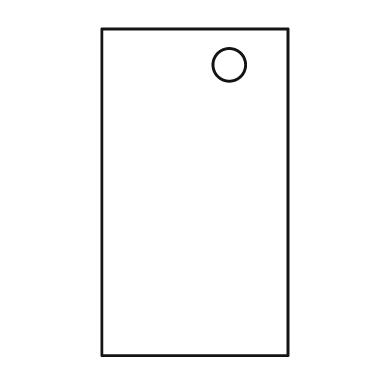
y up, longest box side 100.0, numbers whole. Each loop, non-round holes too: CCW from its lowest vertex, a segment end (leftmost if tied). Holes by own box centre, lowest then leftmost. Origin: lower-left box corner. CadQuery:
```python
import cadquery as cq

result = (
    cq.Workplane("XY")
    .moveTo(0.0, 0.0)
    .lineTo(57.0, 0.0)
    .lineTo(57.0, 100.0)
    .lineTo(0.0, 100.0)
    .close()
    .moveTo(39.0, 89.0)
    .circle(5.0)
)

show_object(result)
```